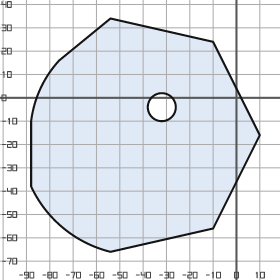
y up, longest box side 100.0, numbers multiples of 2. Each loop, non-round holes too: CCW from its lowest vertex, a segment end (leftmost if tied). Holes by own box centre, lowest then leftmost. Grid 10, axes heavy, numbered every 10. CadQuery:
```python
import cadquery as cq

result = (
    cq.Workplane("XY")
    .moveTo(-54.0, -66.0)
    .lineTo(-10.0, -56.0)
    .lineTo(10.0, -16.0)
    .lineTo(-10.0, 24.0)
    .lineTo(-54.0, 34.0)
    .lineTo(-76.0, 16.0)
    .threePointArc((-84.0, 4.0), (-88.0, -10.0))
    .lineTo(-88.0, -38.0)
    .threePointArc((-74.0, -56.0), (-54.0, -66.0))
    .close()
    .moveTo(-32.0, -4.0)
    .circle(6.0)
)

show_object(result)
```